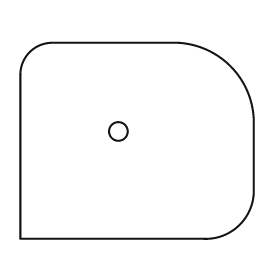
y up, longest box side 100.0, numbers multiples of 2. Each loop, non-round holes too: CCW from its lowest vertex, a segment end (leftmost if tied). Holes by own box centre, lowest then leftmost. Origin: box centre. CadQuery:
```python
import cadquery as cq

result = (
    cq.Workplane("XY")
    .moveTo(-50.0, -42.0)
    .lineTo(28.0, -42.0)
    .threePointArc((44.0, -36.0), (50.0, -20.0))
    .lineTo(50.0, 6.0)
    .threePointArc((40.0, 32.0), (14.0, 42.0))
    .lineTo(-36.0, 42.0)
    .threePointArc((-46.0, 38.0), (-50.0, 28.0))
    .close()
    .moveTo(-8.0, 4.0)
    .circle(4.0)
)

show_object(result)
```